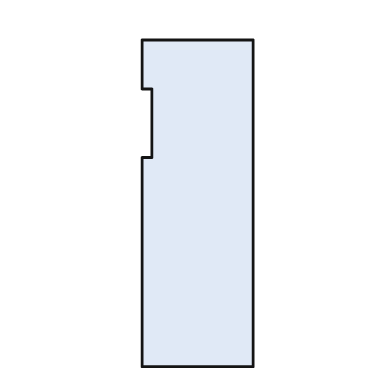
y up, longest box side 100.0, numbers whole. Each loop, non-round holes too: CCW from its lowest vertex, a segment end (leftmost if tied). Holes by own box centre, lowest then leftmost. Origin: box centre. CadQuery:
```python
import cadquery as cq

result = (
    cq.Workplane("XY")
    .moveTo(-17.0, -50.0)
    .lineTo(17.0, -50.0)
    .lineTo(17.0, 50.0)
    .lineTo(-17.0, 50.0)
    .lineTo(-17.0, 35.0)
    .lineTo(-14.0, 35.0)
    .lineTo(-14.0, 14.0)
    .lineTo(-17.0, 14.0)
    .close()
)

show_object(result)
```